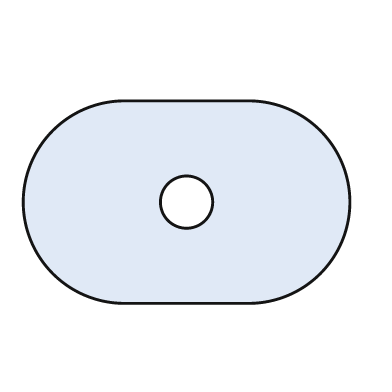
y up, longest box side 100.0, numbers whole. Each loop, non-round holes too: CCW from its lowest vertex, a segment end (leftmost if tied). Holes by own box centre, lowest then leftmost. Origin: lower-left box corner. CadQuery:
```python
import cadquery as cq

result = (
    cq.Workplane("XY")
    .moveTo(31.0, 0.0)
    .lineTo(69.0, 0.0)
    .threePointArc((100.0, 31.0), (69.0, 62.0))
    .lineTo(31.0, 62.0)
    .threePointArc((0.0, 31.0), (31.0, 0.0))
    .close()
    .moveTo(50.0, 31.0)
    .circle(8.0)
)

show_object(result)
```